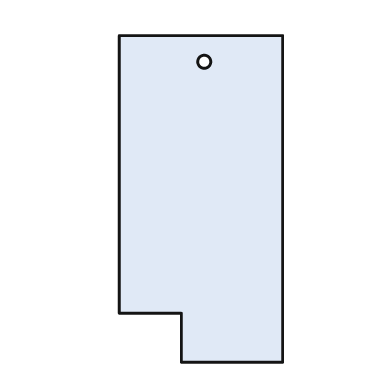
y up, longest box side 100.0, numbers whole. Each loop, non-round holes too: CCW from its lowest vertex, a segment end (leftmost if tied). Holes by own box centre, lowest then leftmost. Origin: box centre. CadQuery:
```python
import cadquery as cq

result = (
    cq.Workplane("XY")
    .moveTo(-6.0, -50.0)
    .lineTo(25.0, -50.0)
    .lineTo(25.0, 50.0)
    .lineTo(-25.0, 50.0)
    .lineTo(-25.0, -35.0)
    .lineTo(-6.0, -35.0)
    .close()
    .moveTo(1.0, 42.0)
    .circle(2.0)
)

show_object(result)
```